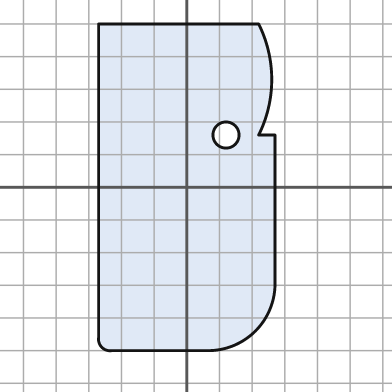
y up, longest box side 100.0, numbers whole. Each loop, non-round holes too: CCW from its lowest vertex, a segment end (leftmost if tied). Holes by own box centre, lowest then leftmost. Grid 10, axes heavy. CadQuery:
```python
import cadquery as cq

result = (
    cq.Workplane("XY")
    .moveTo(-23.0, -50.0)
    .lineTo(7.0, -50.0)
    .threePointArc((21.0, -44.0), (27.0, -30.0))
    .lineTo(27.0, 16.0)
    .lineTo(22.0, 16.0)
    .threePointArc((26.0, 33.0), (22.0, 50.0))
    .lineTo(-27.0, 50.0)
    .lineTo(-27.0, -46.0)
    .threePointArc((-26.0, -49.0), (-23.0, -50.0))
    .close()
    .moveTo(12.0, 16.0)
    .circle(4.0)
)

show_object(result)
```